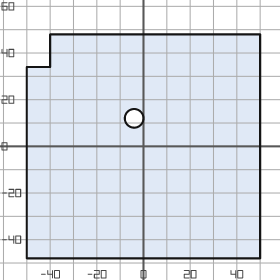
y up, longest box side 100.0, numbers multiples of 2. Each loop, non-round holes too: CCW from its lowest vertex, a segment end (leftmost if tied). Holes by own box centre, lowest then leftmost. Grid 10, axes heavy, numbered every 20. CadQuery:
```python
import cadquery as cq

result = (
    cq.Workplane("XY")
    .moveTo(-50.0, -48.0)
    .lineTo(50.0, -48.0)
    .lineTo(50.0, 48.0)
    .lineTo(-40.0, 48.0)
    .lineTo(-40.0, 34.0)
    .lineTo(-50.0, 34.0)
    .close()
    .moveTo(-4.0, 12.0)
    .circle(4.0)
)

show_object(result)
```